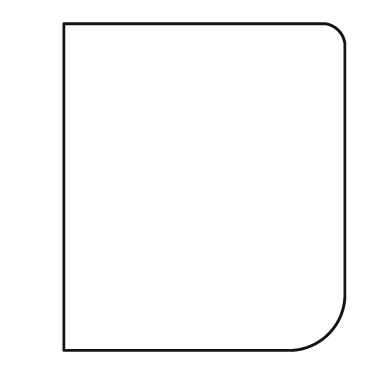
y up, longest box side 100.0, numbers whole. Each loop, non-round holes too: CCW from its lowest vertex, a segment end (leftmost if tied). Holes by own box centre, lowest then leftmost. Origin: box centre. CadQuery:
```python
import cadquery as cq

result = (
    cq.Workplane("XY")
    .moveTo(-43.0, -50.0)
    .lineTo(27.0, -50.0)
    .threePointArc((38.0, -45.0), (43.0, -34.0))
    .lineTo(43.0, 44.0)
    .threePointArc((41.0, 48.0), (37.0, 50.0))
    .lineTo(-43.0, 50.0)
    .close()
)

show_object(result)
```